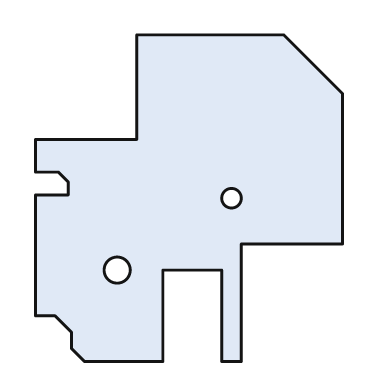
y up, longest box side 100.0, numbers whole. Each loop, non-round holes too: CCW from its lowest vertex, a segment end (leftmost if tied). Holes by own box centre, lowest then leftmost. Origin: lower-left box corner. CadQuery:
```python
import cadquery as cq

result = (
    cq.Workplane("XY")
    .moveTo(15.0, 0.0)
    .lineTo(39.0, 0.0)
    .lineTo(39.0, 28.0)
    .lineTo(57.0, 28.0)
    .lineTo(57.0, 0.0)
    .lineTo(63.0, 0.0)
    .lineTo(63.0, 36.0)
    .lineTo(94.0, 36.0)
    .lineTo(94.0, 82.0)
    .lineTo(76.0, 100.0)
    .lineTo(31.0, 100.0)
    .lineTo(31.0, 68.0)
    .lineTo(0.0, 68.0)
    .lineTo(0.0, 58.0)
    .lineTo(7.0, 58.0)
    .lineTo(10.0, 55.0)
    .lineTo(10.0, 51.0)
    .lineTo(0.0, 51.0)
    .lineTo(0.0, 14.0)
    .lineTo(6.0, 14.0)
    .lineTo(11.0, 9.0)
    .lineTo(11.0, 4.0)
    .close()
    .moveTo(25.0, 28.0)
    .circle(4.0)
    .moveTo(60.0, 50.0)
    .circle(3.0)
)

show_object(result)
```